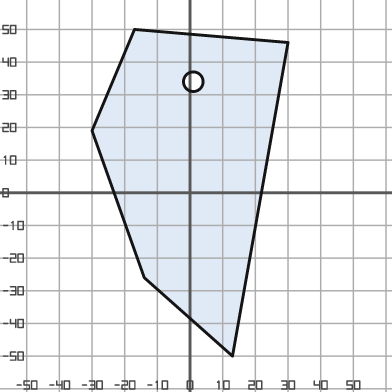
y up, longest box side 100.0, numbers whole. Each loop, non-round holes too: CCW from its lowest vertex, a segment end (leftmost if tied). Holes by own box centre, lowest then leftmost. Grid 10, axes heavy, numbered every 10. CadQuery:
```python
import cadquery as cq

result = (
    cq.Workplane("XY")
    .moveTo(13.0, -50.0)
    .lineTo(30.0, 46.0)
    .lineTo(-17.0, 50.0)
    .lineTo(-30.0, 19.0)
    .lineTo(-14.0, -26.0)
    .close()
    .moveTo(1.0, 34.0)
    .circle(3.0)
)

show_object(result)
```